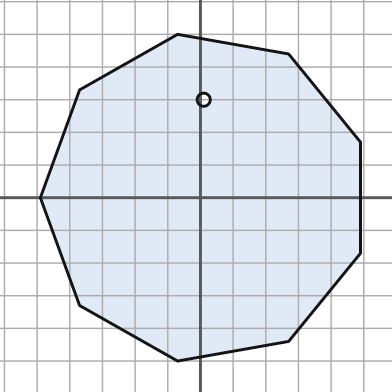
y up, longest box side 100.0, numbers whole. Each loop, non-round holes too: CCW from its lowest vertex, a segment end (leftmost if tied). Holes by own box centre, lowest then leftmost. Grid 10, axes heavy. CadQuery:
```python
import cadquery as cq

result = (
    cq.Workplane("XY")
    .moveTo(-7.0, -50.0)
    .lineTo(27.0, -44.0)
    .lineTo(49.0, -17.0)
    .lineTo(49.0, 17.0)
    .lineTo(27.0, 44.0)
    .lineTo(-7.0, 50.0)
    .lineTo(-37.0, 33.0)
    .lineTo(-49.0, 0.0)
    .lineTo(-37.0, -33.0)
    .close()
    .moveTo(1.0, 30.0)
    .circle(2.0)
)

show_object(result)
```